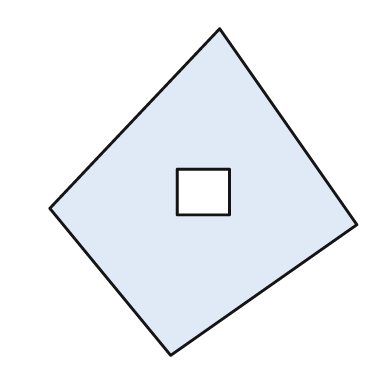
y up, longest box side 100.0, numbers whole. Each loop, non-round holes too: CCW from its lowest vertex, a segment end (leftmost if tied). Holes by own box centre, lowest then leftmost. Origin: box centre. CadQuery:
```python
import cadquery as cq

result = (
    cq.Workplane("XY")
    .moveTo(-10.0, -50.0)
    .lineTo(47.0, -10.0)
    .lineTo(5.0, 50.0)
    .lineTo(-47.0, -5.0)
    .close()
    .moveTo(-8.0, -7.0)
    .lineTo(8.0, -7.0)
    .lineTo(8.0, 7.0)
    .lineTo(-8.0, 7.0)
    .close()
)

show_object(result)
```